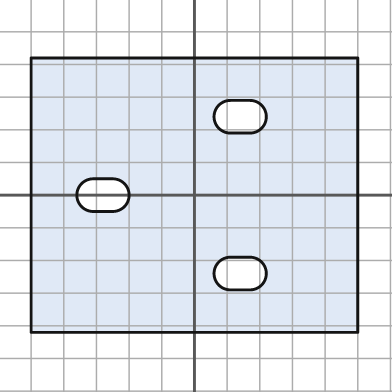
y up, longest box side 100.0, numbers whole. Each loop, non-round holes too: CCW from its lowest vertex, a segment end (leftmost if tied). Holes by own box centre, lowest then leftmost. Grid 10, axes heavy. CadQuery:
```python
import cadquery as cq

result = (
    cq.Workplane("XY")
    .moveTo(-50.0, -42.0)
    .lineTo(50.0, -42.0)
    .lineTo(50.0, 42.0)
    .lineTo(-50.0, 42.0)
    .close()
    .moveTo(11.0, -29.0)
    .lineTo(17.0, -29.0)
    .threePointArc((22.0, -24.0), (17.0, -19.0))
    .lineTo(11.0, -19.0)
    .threePointArc((6.0, -24.0), (11.0, -29.0))
    .close()
    .moveTo(-31.0, -5.0)
    .lineTo(-25.0, -5.0)
    .threePointArc((-20.0, 0.0), (-25.0, 5.0))
    .lineTo(-31.0, 5.0)
    .threePointArc((-36.0, 0.0), (-31.0, -5.0))
    .close()
    .moveTo(11.0, 19.0)
    .lineTo(17.0, 19.0)
    .threePointArc((22.0, 24.0), (17.0, 29.0))
    .lineTo(11.0, 29.0)
    .threePointArc((6.0, 24.0), (11.0, 19.0))
    .close()
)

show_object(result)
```